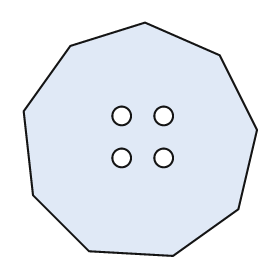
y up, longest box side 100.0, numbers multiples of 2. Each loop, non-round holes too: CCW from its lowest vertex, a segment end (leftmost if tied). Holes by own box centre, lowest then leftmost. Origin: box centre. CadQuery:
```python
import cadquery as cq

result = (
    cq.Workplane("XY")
    .moveTo(14.0, -50.0)
    .lineTo(42.0, -30.0)
    .lineTo(50.0, 4.0)
    .lineTo(34.0, 36.0)
    .lineTo(2.0, 50.0)
    .lineTo(-30.0, 40.0)
    .lineTo(-50.0, 12.0)
    .lineTo(-46.0, -24.0)
    .lineTo(-22.0, -48.0)
    .close()
    .moveTo(-8.0, -8.0)
    .circle(4.0)
    .moveTo(10.0, -8.0)
    .circle(4.0)
    .moveTo(-8.0, 10.0)
    .circle(4.0)
    .moveTo(10.0, 10.0)
    .circle(4.0)
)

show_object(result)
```